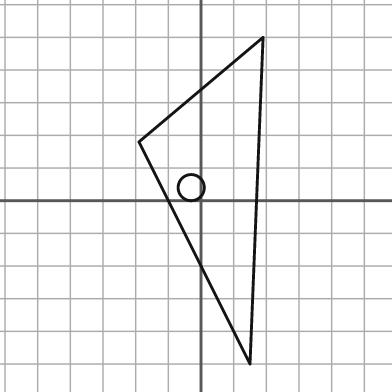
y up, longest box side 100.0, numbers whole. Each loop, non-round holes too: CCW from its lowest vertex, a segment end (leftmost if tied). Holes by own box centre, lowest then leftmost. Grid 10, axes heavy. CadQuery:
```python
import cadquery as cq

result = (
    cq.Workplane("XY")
    .moveTo(15.0, -50.0)
    .lineTo(19.0, 50.0)
    .lineTo(-19.0, 18.0)
    .close()
    .moveTo(-3.0, 4.0)
    .circle(4.0)
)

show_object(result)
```